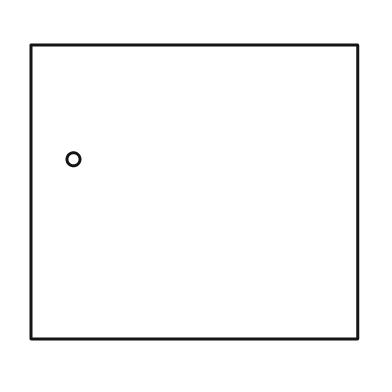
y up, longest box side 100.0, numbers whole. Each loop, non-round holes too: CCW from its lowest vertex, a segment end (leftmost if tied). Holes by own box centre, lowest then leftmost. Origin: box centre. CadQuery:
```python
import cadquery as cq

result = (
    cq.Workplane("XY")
    .moveTo(-50.0, -45.0)
    .lineTo(50.0, -45.0)
    .lineTo(50.0, 45.0)
    .lineTo(-50.0, 45.0)
    .close()
    .moveTo(-37.0, 10.0)
    .circle(2.0)
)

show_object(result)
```